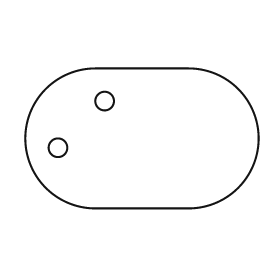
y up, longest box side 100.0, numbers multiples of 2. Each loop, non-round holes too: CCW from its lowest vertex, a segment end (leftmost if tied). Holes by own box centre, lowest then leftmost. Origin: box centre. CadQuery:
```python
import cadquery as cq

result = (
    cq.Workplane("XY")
    .moveTo(-20.0, -30.0)
    .lineTo(20.0, -30.0)
    .threePointArc((50.0, 0.0), (20.0, 30.0))
    .lineTo(-20.0, 30.0)
    .threePointArc((-50.0, 0.0), (-20.0, -30.0))
    .close()
    .moveTo(-36.0, -4.0)
    .circle(4.0)
    .moveTo(-16.0, 16.0)
    .circle(4.0)
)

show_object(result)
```